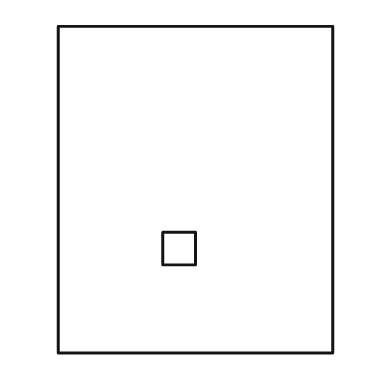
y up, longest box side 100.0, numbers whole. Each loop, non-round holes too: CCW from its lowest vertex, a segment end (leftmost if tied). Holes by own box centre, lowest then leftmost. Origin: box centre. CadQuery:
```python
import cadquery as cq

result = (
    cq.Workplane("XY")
    .moveTo(-42.0, -50.0)
    .lineTo(42.0, -50.0)
    .lineTo(42.0, 50.0)
    .lineTo(-42.0, 50.0)
    .close()
    .moveTo(-10.0, -23.0)
    .lineTo(0.0, -23.0)
    .lineTo(0.0, -13.0)
    .lineTo(-10.0, -13.0)
    .close()
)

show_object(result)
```